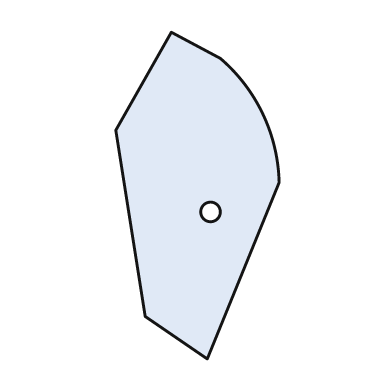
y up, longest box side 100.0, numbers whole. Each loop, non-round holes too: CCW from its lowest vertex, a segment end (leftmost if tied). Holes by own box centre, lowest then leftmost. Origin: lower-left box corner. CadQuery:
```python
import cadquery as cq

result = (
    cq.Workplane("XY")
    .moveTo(28.0, 0.0)
    .lineTo(50.0, 54.0)
    .threePointArc((45.0, 75.0), (32.0, 92.0))
    .lineTo(17.0, 100.0)
    .lineTo(0.0, 70.0)
    .lineTo(9.0, 13.0)
    .close()
    .moveTo(29.0, 45.0)
    .circle(3.0)
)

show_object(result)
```